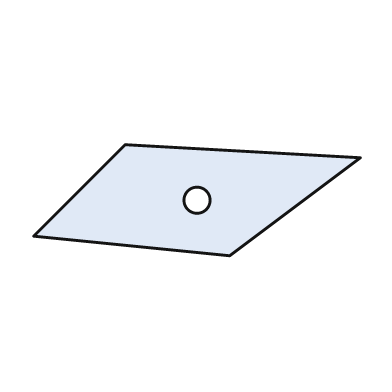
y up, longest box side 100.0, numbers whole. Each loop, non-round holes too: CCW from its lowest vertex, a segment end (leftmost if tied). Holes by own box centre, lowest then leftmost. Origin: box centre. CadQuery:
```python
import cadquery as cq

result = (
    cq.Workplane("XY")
    .moveTo(10.0, -17.0)
    .lineTo(50.0, 13.0)
    .lineTo(-22.0, 17.0)
    .lineTo(-50.0, -11.0)
    .close()
    .moveTo(0.0, 0.0)
    .circle(4.0)
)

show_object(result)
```